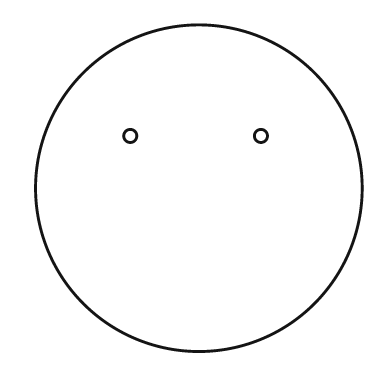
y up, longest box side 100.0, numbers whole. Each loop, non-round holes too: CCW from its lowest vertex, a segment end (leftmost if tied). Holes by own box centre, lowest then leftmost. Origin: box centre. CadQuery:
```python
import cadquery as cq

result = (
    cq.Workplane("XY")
    .moveTo(0.0, 0.0)
    .circle(50.0)
    .moveTo(-21.0, 16.0)
    .circle(2.0)
    .moveTo(19.0, 16.0)
    .circle(2.0)
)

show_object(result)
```